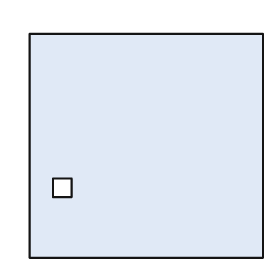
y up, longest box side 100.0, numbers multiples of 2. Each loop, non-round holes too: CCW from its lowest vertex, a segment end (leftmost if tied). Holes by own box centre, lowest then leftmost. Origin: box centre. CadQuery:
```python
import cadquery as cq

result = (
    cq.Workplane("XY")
    .moveTo(-50.0, -48.0)
    .lineTo(50.0, -48.0)
    .lineTo(50.0, 48.0)
    .lineTo(-50.0, 48.0)
    .close()
    .moveTo(-40.0, -22.0)
    .lineTo(-32.0, -22.0)
    .lineTo(-32.0, -14.0)
    .lineTo(-40.0, -14.0)
    .close()
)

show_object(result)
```